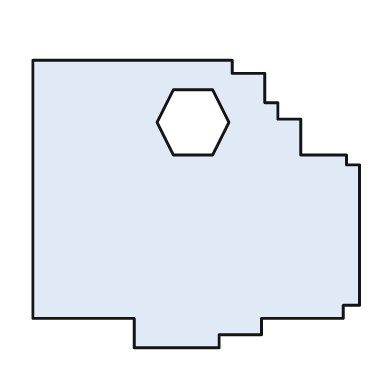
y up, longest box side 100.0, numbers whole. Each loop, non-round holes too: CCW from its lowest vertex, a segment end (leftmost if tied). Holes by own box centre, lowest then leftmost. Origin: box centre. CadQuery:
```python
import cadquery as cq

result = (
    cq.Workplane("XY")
    .moveTo(-19.0, -44.0)
    .lineTo(7.0, -44.0)
    .lineTo(7.0, -40.0)
    .lineTo(20.0, -40.0)
    .lineTo(20.0, -35.0)
    .lineTo(45.0, -35.0)
    .lineTo(45.0, -31.0)
    .lineTo(50.0, -31.0)
    .lineTo(50.0, 12.0)
    .lineTo(46.0, 12.0)
    .lineTo(46.0, 15.0)
    .lineTo(32.0, 15.0)
    .lineTo(32.0, 26.0)
    .lineTo(25.0, 26.0)
    .lineTo(25.0, 31.0)
    .lineTo(21.0, 31.0)
    .lineTo(21.0, 40.0)
    .lineTo(11.0, 40.0)
    .lineTo(11.0, 44.0)
    .lineTo(-50.0, 44.0)
    .lineTo(-50.0, -35.0)
    .lineTo(-19.0, -35.0)
    .close()
    .moveTo(-7.0, 15.0)
    .lineTo(5.0, 15.0)
    .lineTo(10.0, 25.0)
    .lineTo(5.0, 35.0)
    .lineTo(-7.0, 35.0)
    .lineTo(-12.0, 25.0)
    .close()
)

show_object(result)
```